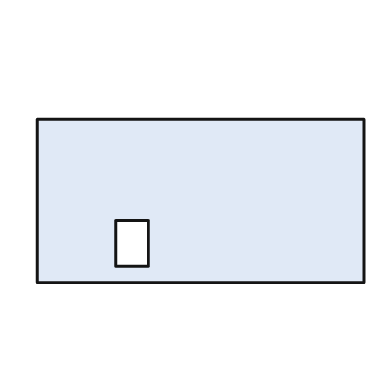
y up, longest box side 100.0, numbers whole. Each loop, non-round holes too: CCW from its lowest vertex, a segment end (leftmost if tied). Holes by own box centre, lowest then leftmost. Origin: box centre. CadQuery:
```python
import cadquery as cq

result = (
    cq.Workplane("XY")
    .moveTo(-50.0, -25.0)
    .lineTo(50.0, -25.0)
    .lineTo(50.0, 25.0)
    .lineTo(-50.0, 25.0)
    .close()
    .moveTo(-26.0, -20.0)
    .lineTo(-16.0, -20.0)
    .lineTo(-16.0, -6.0)
    .lineTo(-26.0, -6.0)
    .close()
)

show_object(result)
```